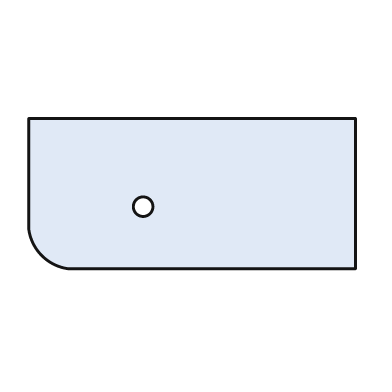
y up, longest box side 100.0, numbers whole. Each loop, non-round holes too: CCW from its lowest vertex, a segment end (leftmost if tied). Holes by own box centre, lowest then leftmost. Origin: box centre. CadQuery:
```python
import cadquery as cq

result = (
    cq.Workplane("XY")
    .moveTo(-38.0, -23.0)
    .lineTo(50.0, -23.0)
    .lineTo(50.0, 23.0)
    .lineTo(-50.0, 23.0)
    .lineTo(-50.0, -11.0)
    .threePointArc((-46.0, -19.0), (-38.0, -23.0))
    .close()
    .moveTo(-15.0, -4.0)
    .circle(3.0)
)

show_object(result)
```